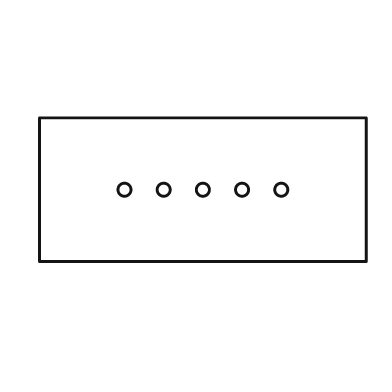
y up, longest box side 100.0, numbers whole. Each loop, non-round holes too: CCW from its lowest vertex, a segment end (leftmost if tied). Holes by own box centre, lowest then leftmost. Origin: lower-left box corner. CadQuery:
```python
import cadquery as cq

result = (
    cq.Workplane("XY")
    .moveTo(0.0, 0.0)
    .lineTo(100.0, 0.0)
    .lineTo(100.0, 44.0)
    .lineTo(0.0, 44.0)
    .close()
    .moveTo(26.0, 22.0)
    .circle(2.0)
    .moveTo(38.0, 22.0)
    .circle(2.0)
    .moveTo(50.0, 22.0)
    .circle(2.0)
    .moveTo(62.0, 22.0)
    .circle(2.0)
    .moveTo(74.0, 22.0)
    .circle(2.0)
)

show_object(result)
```